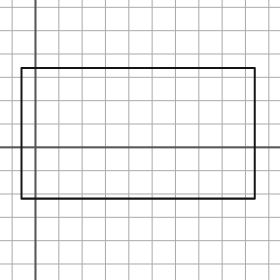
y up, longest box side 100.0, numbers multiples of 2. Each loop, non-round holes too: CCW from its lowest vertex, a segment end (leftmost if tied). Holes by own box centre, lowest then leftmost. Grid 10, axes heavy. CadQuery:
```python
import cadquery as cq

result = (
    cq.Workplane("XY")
    .moveTo(-6.0, -22.0)
    .lineTo(94.0, -22.0)
    .lineTo(94.0, 34.0)
    .lineTo(-6.0, 34.0)
    .close()
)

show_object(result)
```